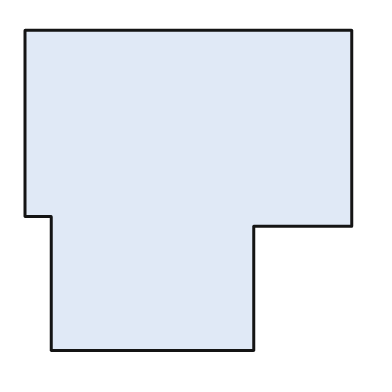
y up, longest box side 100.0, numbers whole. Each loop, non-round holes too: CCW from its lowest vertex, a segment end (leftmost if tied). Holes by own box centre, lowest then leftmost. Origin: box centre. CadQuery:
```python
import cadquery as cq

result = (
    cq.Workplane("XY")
    .moveTo(-42.0, -49.0)
    .lineTo(20.0, -49.0)
    .lineTo(20.0, -11.0)
    .lineTo(50.0, -11.0)
    .lineTo(50.0, 49.0)
    .lineTo(-50.0, 49.0)
    .lineTo(-50.0, -8.0)
    .lineTo(-42.0, -8.0)
    .close()
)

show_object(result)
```